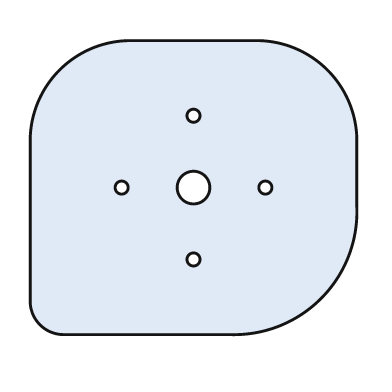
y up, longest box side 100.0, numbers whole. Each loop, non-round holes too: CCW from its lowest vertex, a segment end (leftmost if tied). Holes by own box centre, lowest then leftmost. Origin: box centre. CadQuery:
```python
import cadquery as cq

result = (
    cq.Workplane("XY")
    .moveTo(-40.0, -45.0)
    .lineTo(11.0, -45.0)
    .threePointArc((39.0, -34.0), (50.0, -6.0))
    .lineTo(50.0, 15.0)
    .threePointArc((41.0, 36.0), (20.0, 45.0))
    .lineTo(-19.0, 45.0)
    .threePointArc((-41.0, 36.0), (-50.0, 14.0))
    .lineTo(-50.0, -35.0)
    .threePointArc((-47.0, -42.0), (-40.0, -45.0))
    .close()
    .moveTo(0.0, -22.0)
    .circle(2.0)
    .moveTo(-22.0, 0.0)
    .circle(2.0)
    .moveTo(0.0, 0.0)
    .circle(5.0)
    .moveTo(22.0, 0.0)
    .circle(2.0)
    .moveTo(0.0, 22.0)
    .circle(2.0)
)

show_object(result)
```